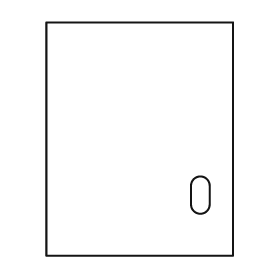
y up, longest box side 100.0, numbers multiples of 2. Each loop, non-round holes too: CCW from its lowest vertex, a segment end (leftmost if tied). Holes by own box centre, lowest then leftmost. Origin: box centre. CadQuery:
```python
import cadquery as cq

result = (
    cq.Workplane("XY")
    .moveTo(-40.0, -50.0)
    .lineTo(40.0, -50.0)
    .lineTo(40.0, 50.0)
    .lineTo(-40.0, 50.0)
    .close()
    .moveTo(22.0, -28.0)
    .threePointArc((26.0, -32.0), (30.0, -28.0))
    .lineTo(30.0, -20.0)
    .threePointArc((26.0, -16.0), (22.0, -20.0))
    .close()
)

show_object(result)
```